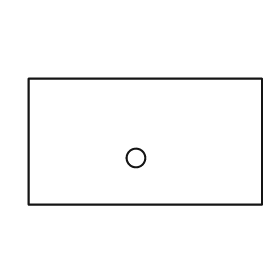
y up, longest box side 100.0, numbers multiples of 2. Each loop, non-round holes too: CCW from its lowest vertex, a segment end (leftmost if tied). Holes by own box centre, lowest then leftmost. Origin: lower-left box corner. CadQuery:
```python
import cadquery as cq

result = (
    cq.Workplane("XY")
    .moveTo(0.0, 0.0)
    .lineTo(100.0, 0.0)
    .lineTo(100.0, 54.0)
    .lineTo(0.0, 54.0)
    .close()
    .moveTo(46.0, 20.0)
    .circle(4.0)
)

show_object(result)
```